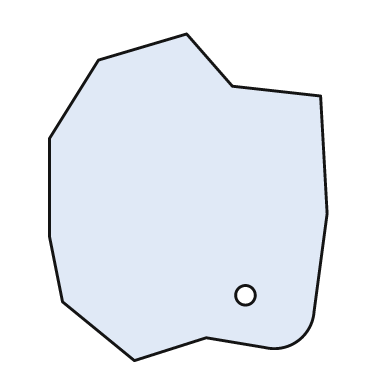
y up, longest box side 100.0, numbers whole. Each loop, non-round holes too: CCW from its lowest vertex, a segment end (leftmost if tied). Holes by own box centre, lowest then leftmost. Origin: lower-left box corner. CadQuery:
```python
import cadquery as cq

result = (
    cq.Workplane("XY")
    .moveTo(26.0, 0.0)
    .lineTo(48.0, 7.0)
    .lineTo(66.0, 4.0)
    .threePointArc((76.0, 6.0), (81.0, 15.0))
    .lineTo(85.0, 45.0)
    .lineTo(83.0, 81.0)
    .lineTo(56.0, 84.0)
    .lineTo(42.0, 100.0)
    .lineTo(15.0, 92.0)
    .lineTo(0.0, 68.0)
    .lineTo(0.0, 38.0)
    .lineTo(4.0, 18.0)
    .close()
    .moveTo(60.0, 20.0)
    .circle(3.0)
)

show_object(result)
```